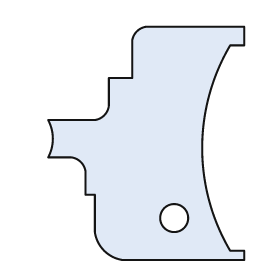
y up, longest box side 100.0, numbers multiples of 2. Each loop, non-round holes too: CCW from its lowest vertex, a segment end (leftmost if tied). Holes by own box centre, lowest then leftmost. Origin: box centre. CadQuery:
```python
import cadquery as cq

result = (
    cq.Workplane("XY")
    .moveTo(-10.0, -50.0)
    .lineTo(42.0, -50.0)
    .lineTo(42.0, -46.0)
    .lineTo(36.0, -46.0)
    .threePointArc((24.0, -2.0), (36.0, 42.0))
    .lineTo(42.0, 42.0)
    .lineTo(42.0, 50.0)
    .lineTo(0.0, 50.0)
    .threePointArc((-4.0, 48.0), (-6.0, 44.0))
    .lineTo(-6.0, 28.0)
    .lineTo(-16.0, 28.0)
    .lineTo(-16.0, 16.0)
    .threePointArc((-18.0, 12.0), (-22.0, 10.0))
    .lineTo(-42.0, 10.0)
    .threePointArc((-40.0, 2.0), (-42.0, -6.0))
    .lineTo(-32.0, -6.0)
    .threePointArc((-28.0, -8.0), (-26.0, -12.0))
    .lineTo(-26.0, -22.0)
    .lineTo(-22.0, -22.0)
    .lineTo(-22.0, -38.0)
    .threePointArc((-18.0, -46.0), (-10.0, -50.0))
    .close()
    .moveTo(12.0, -32.0)
    .circle(6.0)
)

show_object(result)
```